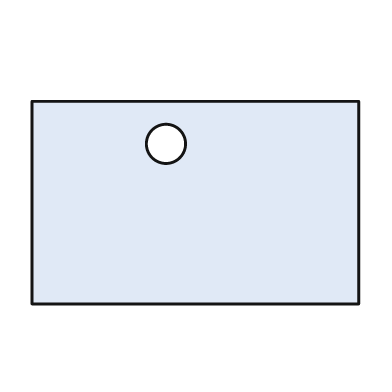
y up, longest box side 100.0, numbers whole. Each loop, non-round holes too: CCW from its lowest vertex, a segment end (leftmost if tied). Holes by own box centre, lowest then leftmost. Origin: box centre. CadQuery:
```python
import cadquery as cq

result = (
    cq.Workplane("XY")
    .moveTo(-50.0, -31.0)
    .lineTo(50.0, -31.0)
    .lineTo(50.0, 31.0)
    .lineTo(-50.0, 31.0)
    .close()
    .moveTo(-9.0, 18.0)
    .circle(6.0)
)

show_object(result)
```